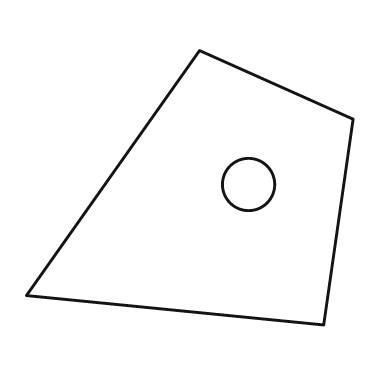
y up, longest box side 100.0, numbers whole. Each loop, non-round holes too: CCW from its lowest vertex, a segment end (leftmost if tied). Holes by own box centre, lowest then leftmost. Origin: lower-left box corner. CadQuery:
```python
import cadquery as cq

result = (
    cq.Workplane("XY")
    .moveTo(91.0, 0.0)
    .lineTo(100.0, 63.0)
    .lineTo(53.0, 84.0)
    .lineTo(0.0, 9.0)
    .close()
    .moveTo(68.0, 43.0)
    .circle(8.0)
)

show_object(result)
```